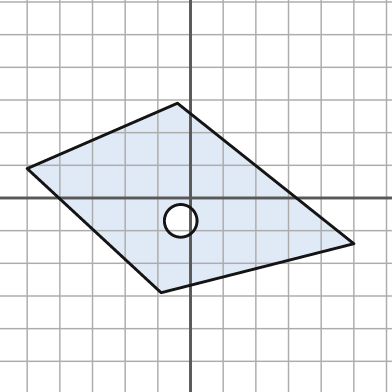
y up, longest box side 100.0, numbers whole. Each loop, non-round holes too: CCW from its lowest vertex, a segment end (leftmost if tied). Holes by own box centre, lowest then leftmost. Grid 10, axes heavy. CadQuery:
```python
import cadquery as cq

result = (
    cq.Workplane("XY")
    .moveTo(-9.0, -29.0)
    .lineTo(50.0, -14.0)
    .lineTo(-4.0, 29.0)
    .lineTo(-50.0, 9.0)
    .close()
    .moveTo(-3.0, -7.0)
    .circle(5.0)
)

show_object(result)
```